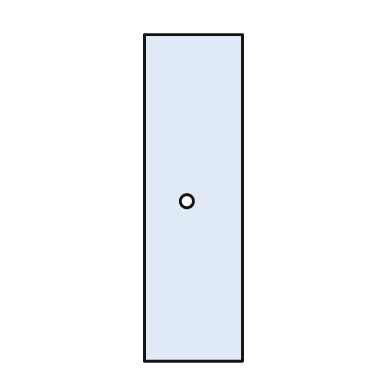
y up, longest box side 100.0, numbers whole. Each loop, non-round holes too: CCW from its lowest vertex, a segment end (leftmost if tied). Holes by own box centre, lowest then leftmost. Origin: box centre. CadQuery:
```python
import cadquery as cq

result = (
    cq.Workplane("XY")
    .moveTo(-15.0, -50.0)
    .lineTo(15.0, -50.0)
    .lineTo(15.0, 50.0)
    .lineTo(-15.0, 50.0)
    .close()
    .moveTo(-2.0, -1.0)
    .circle(2.0)
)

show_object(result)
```